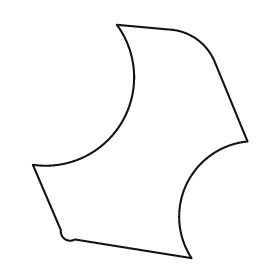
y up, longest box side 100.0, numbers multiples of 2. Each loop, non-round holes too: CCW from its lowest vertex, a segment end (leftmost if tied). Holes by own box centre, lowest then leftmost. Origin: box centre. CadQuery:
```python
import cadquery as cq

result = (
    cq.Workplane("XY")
    .moveTo(22.0, -50.0)
    .threePointArc((20.0, -18.0), (46.0, 0.0))
    .lineTo(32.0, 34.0)
    .threePointArc((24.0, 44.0), (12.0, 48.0))
    .lineTo(-10.0, 50.0)
    .threePointArc((-8.0, 8.0), (-46.0, -10.0))
    .lineTo(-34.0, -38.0)
    .threePointArc((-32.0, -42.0), (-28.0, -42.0))
    .close()
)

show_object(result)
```